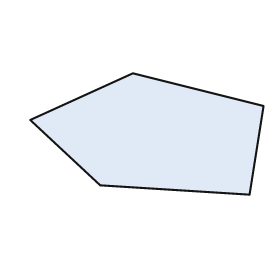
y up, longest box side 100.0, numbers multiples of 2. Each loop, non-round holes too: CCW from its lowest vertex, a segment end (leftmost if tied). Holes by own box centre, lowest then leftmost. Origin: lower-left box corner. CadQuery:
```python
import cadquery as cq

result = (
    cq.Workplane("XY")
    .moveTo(94.0, 0.0)
    .lineTo(100.0, 38.0)
    .lineTo(44.0, 52.0)
    .lineTo(0.0, 32.0)
    .lineTo(30.0, 4.0)
    .close()
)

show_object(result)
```